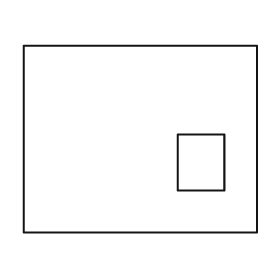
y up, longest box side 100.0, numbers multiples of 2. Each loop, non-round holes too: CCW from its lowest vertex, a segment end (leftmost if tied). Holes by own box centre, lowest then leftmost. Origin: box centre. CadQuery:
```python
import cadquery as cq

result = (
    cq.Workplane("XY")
    .moveTo(-50.0, -40.0)
    .lineTo(50.0, -40.0)
    .lineTo(50.0, 40.0)
    .lineTo(-50.0, 40.0)
    .close()
    .moveTo(16.0, -22.0)
    .lineTo(36.0, -22.0)
    .lineTo(36.0, 2.0)
    .lineTo(16.0, 2.0)
    .close()
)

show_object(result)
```